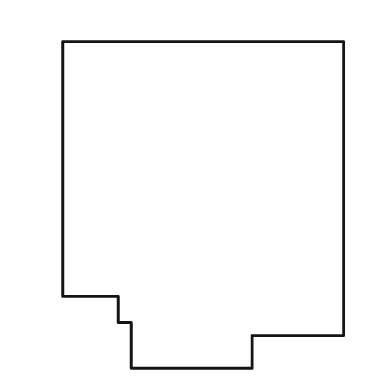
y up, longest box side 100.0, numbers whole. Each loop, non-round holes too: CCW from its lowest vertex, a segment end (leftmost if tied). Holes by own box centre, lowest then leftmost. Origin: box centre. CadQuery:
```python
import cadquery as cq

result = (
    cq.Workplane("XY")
    .moveTo(-22.0, -50.0)
    .lineTo(15.0, -50.0)
    .lineTo(15.0, -40.0)
    .lineTo(43.0, -40.0)
    .lineTo(43.0, 50.0)
    .lineTo(-43.0, 50.0)
    .lineTo(-43.0, -28.0)
    .lineTo(-26.0, -28.0)
    .lineTo(-26.0, -36.0)
    .lineTo(-22.0, -36.0)
    .close()
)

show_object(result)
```